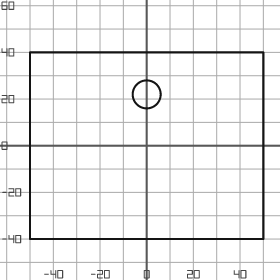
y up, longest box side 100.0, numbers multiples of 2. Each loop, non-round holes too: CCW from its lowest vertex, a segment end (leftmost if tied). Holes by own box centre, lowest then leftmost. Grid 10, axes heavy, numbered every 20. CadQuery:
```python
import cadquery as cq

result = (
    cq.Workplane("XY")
    .moveTo(-50.0, -40.0)
    .lineTo(50.0, -40.0)
    .lineTo(50.0, 40.0)
    .lineTo(-50.0, 40.0)
    .close()
    .moveTo(0.0, 22.0)
    .circle(6.0)
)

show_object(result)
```